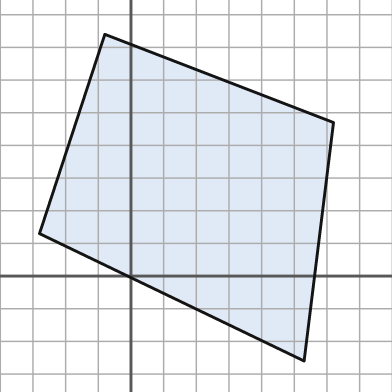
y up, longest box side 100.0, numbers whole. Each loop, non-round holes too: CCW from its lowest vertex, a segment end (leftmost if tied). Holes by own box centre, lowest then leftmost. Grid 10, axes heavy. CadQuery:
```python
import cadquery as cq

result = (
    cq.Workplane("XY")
    .moveTo(53.0, -26.0)
    .lineTo(62.0, 47.0)
    .lineTo(-8.0, 74.0)
    .lineTo(-28.0, 13.0)
    .close()
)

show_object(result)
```